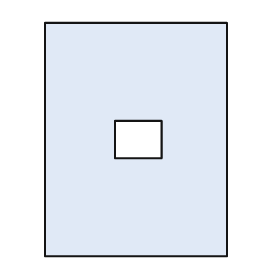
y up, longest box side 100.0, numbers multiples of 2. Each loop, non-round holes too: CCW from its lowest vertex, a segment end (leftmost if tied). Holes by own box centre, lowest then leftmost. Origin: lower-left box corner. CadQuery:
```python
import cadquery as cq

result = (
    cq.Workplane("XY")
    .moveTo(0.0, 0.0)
    .lineTo(78.0, 0.0)
    .lineTo(78.0, 100.0)
    .lineTo(0.0, 100.0)
    .close()
    .moveTo(30.0, 42.0)
    .lineTo(50.0, 42.0)
    .lineTo(50.0, 58.0)
    .lineTo(30.0, 58.0)
    .close()
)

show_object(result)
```